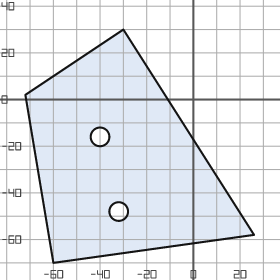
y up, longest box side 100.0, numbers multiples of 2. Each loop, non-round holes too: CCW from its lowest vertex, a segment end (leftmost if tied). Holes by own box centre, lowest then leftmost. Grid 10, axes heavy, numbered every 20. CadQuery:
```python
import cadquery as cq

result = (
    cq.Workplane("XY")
    .moveTo(-60.0, -70.0)
    .lineTo(26.0, -58.0)
    .lineTo(-30.0, 30.0)
    .lineTo(-72.0, 2.0)
    .close()
    .moveTo(-32.0, -48.0)
    .circle(4.0)
    .moveTo(-40.0, -16.0)
    .circle(4.0)
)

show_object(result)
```